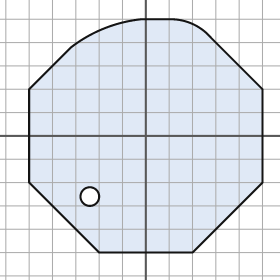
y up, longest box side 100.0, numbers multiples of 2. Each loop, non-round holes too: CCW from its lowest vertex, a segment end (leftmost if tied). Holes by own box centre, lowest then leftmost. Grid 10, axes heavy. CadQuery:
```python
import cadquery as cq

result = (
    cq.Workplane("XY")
    .moveTo(-20.0, -50.0)
    .lineTo(20.0, -50.0)
    .lineTo(50.0, -20.0)
    .lineTo(50.0, 20.0)
    .lineTo(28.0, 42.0)
    .threePointArc((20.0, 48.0), (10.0, 50.0))
    .lineTo(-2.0, 50.0)
    .threePointArc((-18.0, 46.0), (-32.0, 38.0))
    .lineTo(-50.0, 20.0)
    .lineTo(-50.0, -20.0)
    .close()
    .moveTo(-24.0, -26.0)
    .circle(4.0)
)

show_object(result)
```